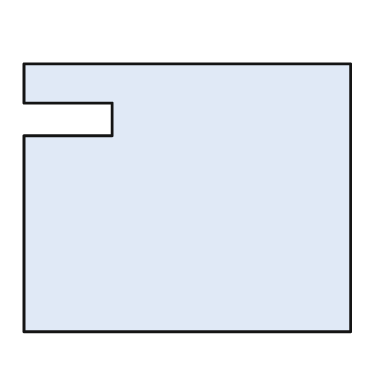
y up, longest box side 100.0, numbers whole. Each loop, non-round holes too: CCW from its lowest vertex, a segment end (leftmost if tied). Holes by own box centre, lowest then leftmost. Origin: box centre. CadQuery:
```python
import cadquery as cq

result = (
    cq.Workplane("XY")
    .moveTo(-50.0, -41.0)
    .lineTo(50.0, -41.0)
    .lineTo(50.0, 41.0)
    .lineTo(-50.0, 41.0)
    .lineTo(-50.0, 29.0)
    .lineTo(-23.0, 29.0)
    .lineTo(-23.0, 19.0)
    .lineTo(-50.0, 19.0)
    .close()
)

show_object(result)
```